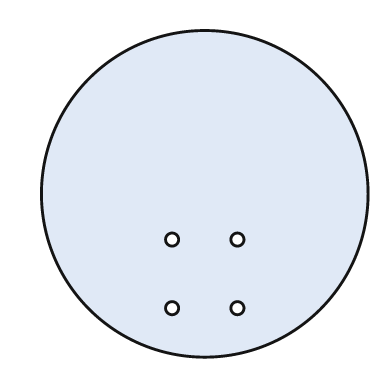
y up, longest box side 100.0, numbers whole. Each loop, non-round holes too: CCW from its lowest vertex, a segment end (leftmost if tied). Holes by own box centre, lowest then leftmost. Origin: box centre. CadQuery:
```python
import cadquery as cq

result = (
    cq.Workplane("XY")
    .moveTo(0.0, 0.0)
    .circle(50.0)
    .moveTo(-10.0, -35.0)
    .circle(2.0)
    .moveTo(10.0, -35.0)
    .circle(2.0)
    .moveTo(-10.0, -14.0)
    .circle(2.0)
    .moveTo(10.0, -14.0)
    .circle(2.0)
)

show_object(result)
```